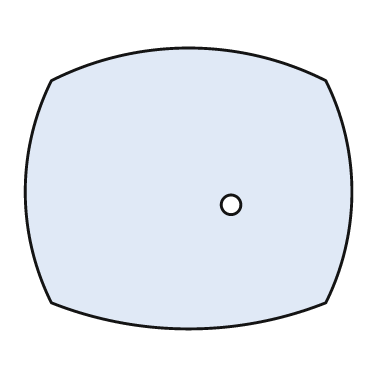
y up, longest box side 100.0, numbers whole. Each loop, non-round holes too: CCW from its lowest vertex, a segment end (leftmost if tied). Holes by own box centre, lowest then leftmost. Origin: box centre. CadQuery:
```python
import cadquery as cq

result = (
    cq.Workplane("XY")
    .moveTo(-42.0, -35.0)
    .threePointArc((0.0, -43.0), (42.0, -35.0))
    .threePointArc((50.0, -1.0), (42.0, 33.0))
    .threePointArc((0.0, 43.0), (-42.0, 33.0))
    .threePointArc((-50.0, -1.0), (-42.0, -35.0))
    .close()
    .moveTo(13.0, -5.0)
    .circle(3.0)
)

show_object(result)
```